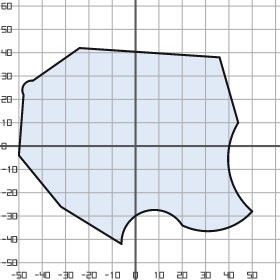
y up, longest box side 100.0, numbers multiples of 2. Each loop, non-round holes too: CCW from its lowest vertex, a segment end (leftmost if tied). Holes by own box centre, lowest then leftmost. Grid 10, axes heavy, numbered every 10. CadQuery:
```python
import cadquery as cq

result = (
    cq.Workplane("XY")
    .moveTo(-6.0, -42.0)
    .threePointArc((4.0, -28.0), (20.0, -34.0))
    .threePointArc((36.0, -36.0), (50.0, -28.0))
    .threePointArc((40.0, -10.0), (44.0, 10.0))
    .lineTo(36.0, 38.0)
    .lineTo(-24.0, 42.0)
    .lineTo(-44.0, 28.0)
    .threePointArc((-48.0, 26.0), (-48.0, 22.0))
    .lineTo(-50.0, -4.0)
    .lineTo(-32.0, -26.0)
    .close()
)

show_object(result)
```